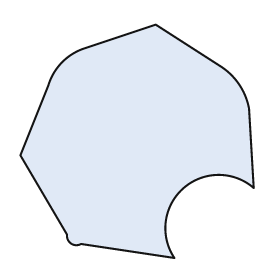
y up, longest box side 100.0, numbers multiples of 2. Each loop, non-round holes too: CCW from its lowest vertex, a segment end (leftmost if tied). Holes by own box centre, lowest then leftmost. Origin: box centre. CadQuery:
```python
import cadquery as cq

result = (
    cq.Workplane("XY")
    .moveTo(16.0, -50.0)
    .threePointArc((20.0, -20.0), (50.0, -20.0))
    .lineTo(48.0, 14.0)
    .threePointArc((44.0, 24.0), (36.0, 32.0))
    .lineTo(8.0, 50.0)
    .lineTo(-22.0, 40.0)
    .threePointArc((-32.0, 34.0), (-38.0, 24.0))
    .lineTo(-50.0, -6.0)
    .lineTo(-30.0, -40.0)
    .threePointArc((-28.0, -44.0), (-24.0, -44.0))
    .close()
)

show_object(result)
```